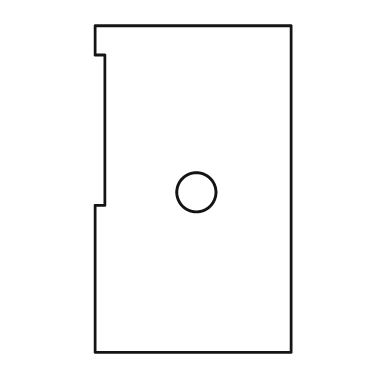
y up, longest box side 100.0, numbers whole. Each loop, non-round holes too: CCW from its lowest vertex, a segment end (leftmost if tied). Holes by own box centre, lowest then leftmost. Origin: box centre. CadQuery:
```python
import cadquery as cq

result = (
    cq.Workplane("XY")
    .moveTo(-30.0, -50.0)
    .lineTo(30.0, -50.0)
    .lineTo(30.0, 50.0)
    .lineTo(-30.0, 50.0)
    .lineTo(-30.0, 41.0)
    .lineTo(-27.0, 41.0)
    .lineTo(-27.0, -5.0)
    .lineTo(-30.0, -5.0)
    .close()
    .moveTo(1.0, -1.0)
    .circle(6.0)
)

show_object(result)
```